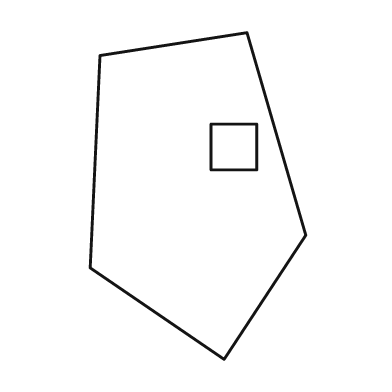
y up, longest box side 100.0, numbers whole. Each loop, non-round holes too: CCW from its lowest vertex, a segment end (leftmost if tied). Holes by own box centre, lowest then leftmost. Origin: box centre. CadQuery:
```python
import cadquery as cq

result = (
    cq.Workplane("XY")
    .moveTo(8.0, -50.0)
    .lineTo(33.0, -12.0)
    .lineTo(15.0, 50.0)
    .lineTo(-30.0, 43.0)
    .lineTo(-33.0, -22.0)
    .close()
    .moveTo(4.0, 8.0)
    .lineTo(18.0, 8.0)
    .lineTo(18.0, 22.0)
    .lineTo(4.0, 22.0)
    .close()
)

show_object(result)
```